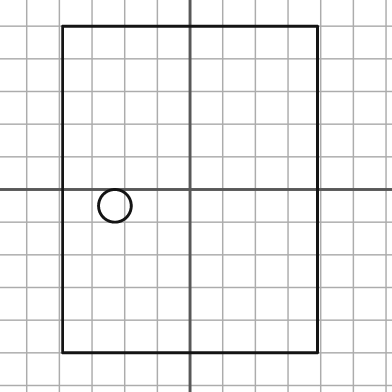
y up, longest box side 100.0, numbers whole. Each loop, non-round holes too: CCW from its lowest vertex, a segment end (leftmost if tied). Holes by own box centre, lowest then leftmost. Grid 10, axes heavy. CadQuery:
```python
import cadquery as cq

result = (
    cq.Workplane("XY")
    .moveTo(-39.0, -50.0)
    .lineTo(39.0, -50.0)
    .lineTo(39.0, 50.0)
    .lineTo(-39.0, 50.0)
    .close()
    .moveTo(-23.0, -5.0)
    .circle(5.0)
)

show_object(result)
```